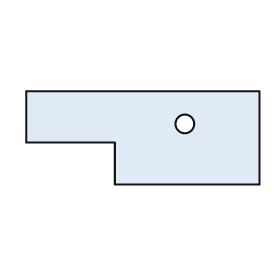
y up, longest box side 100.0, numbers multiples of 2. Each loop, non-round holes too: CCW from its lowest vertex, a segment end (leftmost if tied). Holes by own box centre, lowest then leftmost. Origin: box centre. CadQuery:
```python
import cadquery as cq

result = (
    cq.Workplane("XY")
    .moveTo(-12.0, -20.0)
    .lineTo(50.0, -20.0)
    .lineTo(50.0, 20.0)
    .lineTo(-50.0, 20.0)
    .lineTo(-50.0, -2.0)
    .lineTo(-12.0, -2.0)
    .close()
    .moveTo(18.0, 6.0)
    .circle(4.0)
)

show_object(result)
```